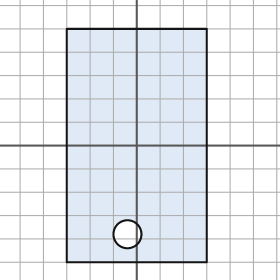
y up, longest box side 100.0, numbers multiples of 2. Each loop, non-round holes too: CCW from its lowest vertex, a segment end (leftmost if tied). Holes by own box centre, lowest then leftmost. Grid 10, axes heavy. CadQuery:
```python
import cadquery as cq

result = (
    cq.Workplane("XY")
    .moveTo(-30.0, -50.0)
    .lineTo(30.0, -50.0)
    .lineTo(30.0, 50.0)
    .lineTo(-30.0, 50.0)
    .close()
    .moveTo(-4.0, -38.0)
    .circle(6.0)
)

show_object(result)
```